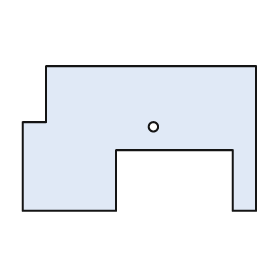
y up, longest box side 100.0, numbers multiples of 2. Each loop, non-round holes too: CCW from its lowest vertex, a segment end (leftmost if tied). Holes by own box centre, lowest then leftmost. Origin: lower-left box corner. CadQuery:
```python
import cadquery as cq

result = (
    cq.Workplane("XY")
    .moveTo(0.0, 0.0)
    .lineTo(40.0, 0.0)
    .lineTo(40.0, 26.0)
    .lineTo(90.0, 26.0)
    .lineTo(90.0, 0.0)
    .lineTo(100.0, 0.0)
    .lineTo(100.0, 62.0)
    .lineTo(10.0, 62.0)
    .lineTo(10.0, 38.0)
    .lineTo(0.0, 38.0)
    .close()
    .moveTo(56.0, 36.0)
    .circle(2.0)
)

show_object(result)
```